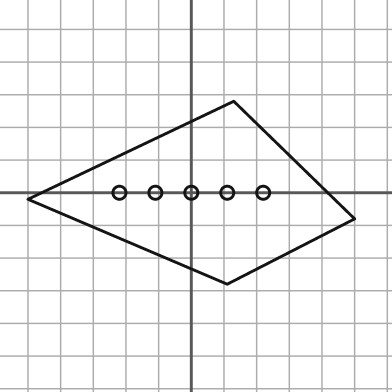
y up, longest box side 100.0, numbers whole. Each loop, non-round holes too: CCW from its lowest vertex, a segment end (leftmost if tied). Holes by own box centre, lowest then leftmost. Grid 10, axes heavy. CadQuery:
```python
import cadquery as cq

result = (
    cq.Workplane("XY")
    .moveTo(11.0, -28.0)
    .lineTo(50.0, -8.0)
    .lineTo(13.0, 28.0)
    .lineTo(-50.0, -2.0)
    .close()
    .moveTo(-22.0, 0.0)
    .circle(2.0)
    .moveTo(-11.0, 0.0)
    .circle(2.0)
    .moveTo(0.0, 0.0)
    .circle(2.0)
    .moveTo(11.0, 0.0)
    .circle(2.0)
    .moveTo(22.0, 0.0)
    .circle(2.0)
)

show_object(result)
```